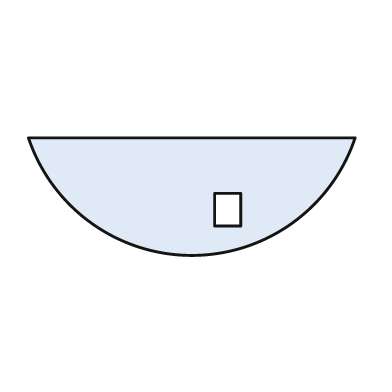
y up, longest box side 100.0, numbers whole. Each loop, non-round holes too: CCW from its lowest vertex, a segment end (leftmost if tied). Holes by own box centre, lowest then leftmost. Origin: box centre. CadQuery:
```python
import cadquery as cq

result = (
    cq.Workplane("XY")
    .moveTo(-50.0, 18.0)
    .threePointArc((0.0, -18.0), (50.0, 18.0))
    .close()
    .moveTo(7.0, -9.0)
    .lineTo(15.0, -9.0)
    .lineTo(15.0, 1.0)
    .lineTo(7.0, 1.0)
    .close()
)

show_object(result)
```